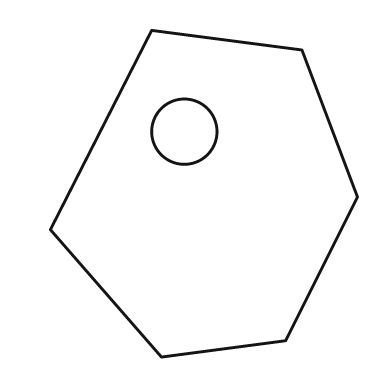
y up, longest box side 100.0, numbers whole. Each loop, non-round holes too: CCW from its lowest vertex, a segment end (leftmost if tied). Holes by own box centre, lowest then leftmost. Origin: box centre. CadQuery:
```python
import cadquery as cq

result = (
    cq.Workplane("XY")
    .moveTo(-13.0, -50.0)
    .lineTo(25.0, -45.0)
    .lineTo(47.0, -1.0)
    .lineTo(30.0, 44.0)
    .lineTo(-16.0, 50.0)
    .lineTo(-47.0, -11.0)
    .close()
    .moveTo(-6.0, 19.0)
    .circle(10.0)
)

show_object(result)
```